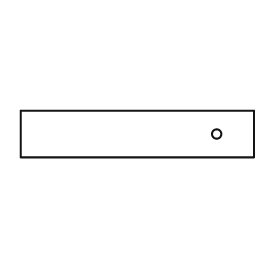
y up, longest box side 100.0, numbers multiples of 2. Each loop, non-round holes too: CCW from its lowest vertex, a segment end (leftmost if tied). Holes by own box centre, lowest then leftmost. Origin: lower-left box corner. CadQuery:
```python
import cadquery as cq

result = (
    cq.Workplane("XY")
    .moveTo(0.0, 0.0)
    .lineTo(100.0, 0.0)
    .lineTo(100.0, 20.0)
    .lineTo(0.0, 20.0)
    .close()
    .moveTo(84.0, 10.0)
    .circle(2.0)
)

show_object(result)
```